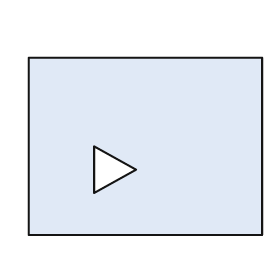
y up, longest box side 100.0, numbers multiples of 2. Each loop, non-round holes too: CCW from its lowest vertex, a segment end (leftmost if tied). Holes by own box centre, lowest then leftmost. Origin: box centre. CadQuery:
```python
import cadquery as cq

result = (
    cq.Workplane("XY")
    .moveTo(-50.0, -38.0)
    .lineTo(50.0, -38.0)
    .lineTo(50.0, 38.0)
    .lineTo(-50.0, 38.0)
    .close()
    .moveTo(-22.0, -20.0)
    .lineTo(-4.0, -10.0)
    .lineTo(-22.0, 0.0)
    .close()
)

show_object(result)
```